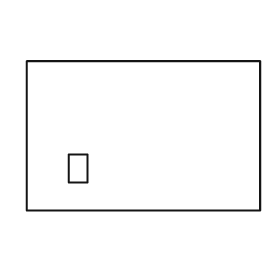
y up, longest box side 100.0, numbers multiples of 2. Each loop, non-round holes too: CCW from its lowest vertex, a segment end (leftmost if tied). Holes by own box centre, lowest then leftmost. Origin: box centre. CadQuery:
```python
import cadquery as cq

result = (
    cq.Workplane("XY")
    .moveTo(-50.0, -32.0)
    .lineTo(50.0, -32.0)
    .lineTo(50.0, 32.0)
    .lineTo(-50.0, 32.0)
    .close()
    .moveTo(-32.0, -20.0)
    .lineTo(-24.0, -20.0)
    .lineTo(-24.0, -8.0)
    .lineTo(-32.0, -8.0)
    .close()
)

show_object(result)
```